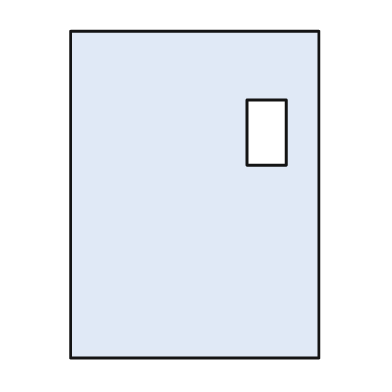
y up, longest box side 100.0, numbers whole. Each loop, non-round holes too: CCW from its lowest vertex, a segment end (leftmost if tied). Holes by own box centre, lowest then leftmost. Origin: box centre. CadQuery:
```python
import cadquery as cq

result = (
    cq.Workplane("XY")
    .moveTo(-38.0, -50.0)
    .lineTo(38.0, -50.0)
    .lineTo(38.0, 50.0)
    .lineTo(-38.0, 50.0)
    .close()
    .moveTo(16.0, 9.0)
    .lineTo(28.0, 9.0)
    .lineTo(28.0, 29.0)
    .lineTo(16.0, 29.0)
    .close()
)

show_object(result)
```